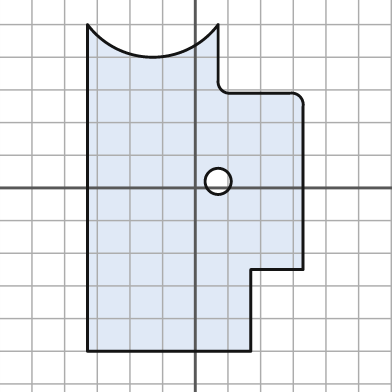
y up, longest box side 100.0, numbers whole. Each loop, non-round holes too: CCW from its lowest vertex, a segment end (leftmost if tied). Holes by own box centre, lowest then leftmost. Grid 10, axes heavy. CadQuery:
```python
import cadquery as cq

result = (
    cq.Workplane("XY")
    .moveTo(-33.0, -50.0)
    .lineTo(17.0, -50.0)
    .lineTo(17.0, -25.0)
    .lineTo(33.0, -25.0)
    .lineTo(33.0, 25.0)
    .threePointArc((32.0, 28.0), (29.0, 29.0))
    .lineTo(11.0, 29.0)
    .threePointArc((8.0, 30.0), (7.0, 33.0))
    .lineTo(7.0, 50.0)
    .threePointArc((-13.0, 40.0), (-33.0, 50.0))
    .close()
    .moveTo(7.0, 2.0)
    .circle(4.0)
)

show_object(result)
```